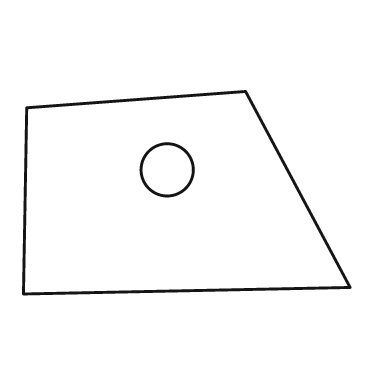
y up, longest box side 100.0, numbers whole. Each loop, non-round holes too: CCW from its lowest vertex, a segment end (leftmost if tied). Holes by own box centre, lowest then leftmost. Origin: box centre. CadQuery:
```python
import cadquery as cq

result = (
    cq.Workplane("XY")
    .moveTo(-50.0, -31.0)
    .lineTo(50.0, -29.0)
    .lineTo(18.0, 31.0)
    .lineTo(-49.0, 26.0)
    .close()
    .moveTo(-6.0, 7.0)
    .circle(8.0)
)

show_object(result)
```